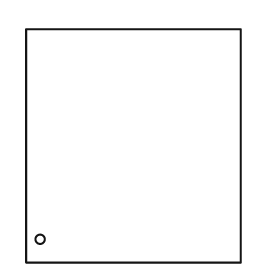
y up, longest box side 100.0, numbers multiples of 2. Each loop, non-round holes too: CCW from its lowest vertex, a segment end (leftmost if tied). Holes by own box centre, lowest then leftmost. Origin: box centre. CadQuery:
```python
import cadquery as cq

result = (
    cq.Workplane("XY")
    .moveTo(-46.0, -50.0)
    .lineTo(46.0, -50.0)
    .lineTo(46.0, 50.0)
    .lineTo(-46.0, 50.0)
    .close()
    .moveTo(-40.0, -40.0)
    .circle(2.0)
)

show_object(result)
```